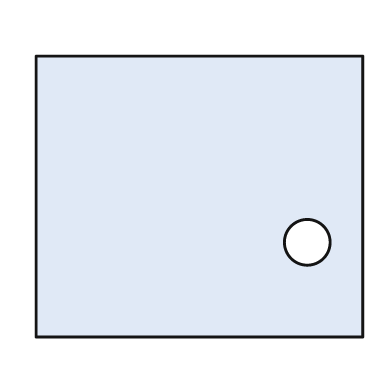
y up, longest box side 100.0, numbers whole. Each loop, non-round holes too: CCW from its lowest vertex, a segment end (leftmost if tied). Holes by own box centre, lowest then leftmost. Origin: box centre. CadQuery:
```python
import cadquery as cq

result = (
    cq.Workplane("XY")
    .moveTo(-50.0, -43.0)
    .lineTo(50.0, -43.0)
    .lineTo(50.0, 43.0)
    .lineTo(-50.0, 43.0)
    .close()
    .moveTo(33.0, -14.0)
    .circle(7.0)
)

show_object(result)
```